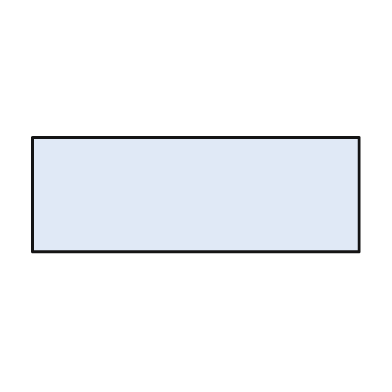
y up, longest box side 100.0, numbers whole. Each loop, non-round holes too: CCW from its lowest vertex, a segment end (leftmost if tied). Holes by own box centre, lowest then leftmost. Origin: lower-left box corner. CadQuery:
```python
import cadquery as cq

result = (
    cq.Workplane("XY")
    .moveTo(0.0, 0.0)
    .lineTo(100.0, 0.0)
    .lineTo(100.0, 35.0)
    .lineTo(0.0, 35.0)
    .close()
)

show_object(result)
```